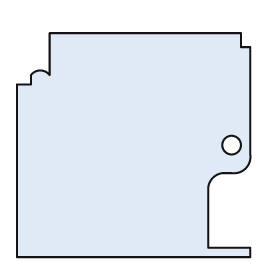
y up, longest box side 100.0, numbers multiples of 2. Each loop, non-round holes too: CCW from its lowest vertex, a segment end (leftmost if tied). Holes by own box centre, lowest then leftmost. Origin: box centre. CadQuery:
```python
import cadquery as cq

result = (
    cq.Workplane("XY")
    .moveTo(-50.0, -48.0)
    .lineTo(50.0, -48.0)
    .lineTo(50.0, -44.0)
    .lineTo(32.0, -44.0)
    .lineTo(32.0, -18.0)
    .threePointArc((34.0, -14.0), (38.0, -12.0))
    .lineTo(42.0, -12.0)
    .threePointArc((48.0, -10.0), (50.0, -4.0))
    .lineTo(50.0, 42.0)
    .lineTo(46.0, 42.0)
    .lineTo(46.0, 48.0)
    .lineTo(-36.0, 48.0)
    .lineTo(-36.0, 30.0)
    .threePointArc((-40.0, 32.0), (-44.0, 30.0))
    .lineTo(-44.0, 26.0)
    .lineTo(-50.0, 26.0)
    .close()
    .moveTo(42.0, 0.0)
    .circle(4.0)
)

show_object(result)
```